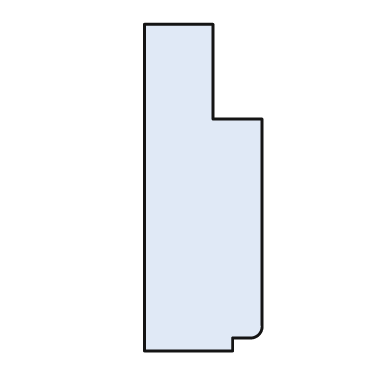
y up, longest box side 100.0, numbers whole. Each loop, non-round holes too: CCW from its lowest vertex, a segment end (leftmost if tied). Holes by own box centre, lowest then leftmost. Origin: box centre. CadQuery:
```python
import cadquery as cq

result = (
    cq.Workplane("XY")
    .moveTo(-18.0, -50.0)
    .lineTo(9.0, -50.0)
    .lineTo(9.0, -46.0)
    .lineTo(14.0, -46.0)
    .threePointArc((17.0, -45.0), (18.0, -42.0))
    .lineTo(18.0, 21.0)
    .lineTo(3.0, 21.0)
    .lineTo(3.0, 50.0)
    .lineTo(-18.0, 50.0)
    .close()
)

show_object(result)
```